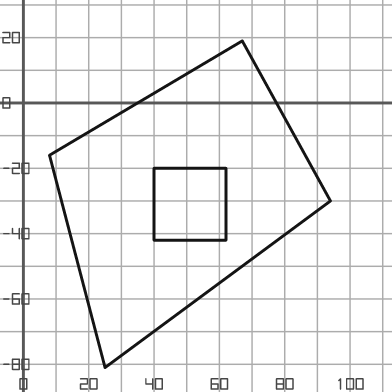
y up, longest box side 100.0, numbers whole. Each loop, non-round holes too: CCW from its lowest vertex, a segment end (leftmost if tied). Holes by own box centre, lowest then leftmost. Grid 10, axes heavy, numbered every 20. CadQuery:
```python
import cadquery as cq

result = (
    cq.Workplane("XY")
    .moveTo(25.0, -81.0)
    .lineTo(94.0, -30.0)
    .lineTo(67.0, 19.0)
    .lineTo(8.0, -16.0)
    .close()
    .moveTo(40.0, -42.0)
    .lineTo(62.0, -42.0)
    .lineTo(62.0, -20.0)
    .lineTo(40.0, -20.0)
    .close()
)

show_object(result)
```